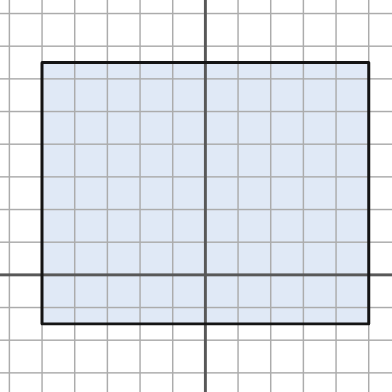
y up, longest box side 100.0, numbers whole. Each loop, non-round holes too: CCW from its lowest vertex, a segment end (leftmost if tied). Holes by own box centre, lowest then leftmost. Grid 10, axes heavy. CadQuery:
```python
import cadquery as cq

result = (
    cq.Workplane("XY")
    .moveTo(-50.0, -15.0)
    .lineTo(50.0, -15.0)
    .lineTo(50.0, 65.0)
    .lineTo(-50.0, 65.0)
    .close()
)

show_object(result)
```